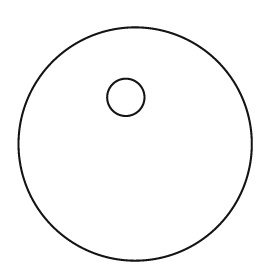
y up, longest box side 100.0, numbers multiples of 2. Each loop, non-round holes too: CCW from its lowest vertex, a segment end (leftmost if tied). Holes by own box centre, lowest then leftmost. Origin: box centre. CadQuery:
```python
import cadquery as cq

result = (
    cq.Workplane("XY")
    .moveTo(0.0, 0.0)
    .circle(50.0)
    .moveTo(-4.0, 20.0)
    .circle(8.0)
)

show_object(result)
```